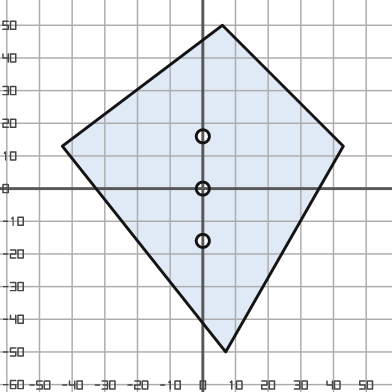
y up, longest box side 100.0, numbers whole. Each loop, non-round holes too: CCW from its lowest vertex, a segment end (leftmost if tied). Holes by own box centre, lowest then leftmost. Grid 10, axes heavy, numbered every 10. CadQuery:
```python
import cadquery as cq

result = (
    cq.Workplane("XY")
    .moveTo(7.0, -50.0)
    .lineTo(43.0, 13.0)
    .lineTo(6.0, 50.0)
    .lineTo(-43.0, 13.0)
    .close()
    .moveTo(0.0, -16.0)
    .circle(2.0)
    .moveTo(0.0, 0.0)
    .circle(2.0)
    .moveTo(0.0, 16.0)
    .circle(2.0)
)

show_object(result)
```